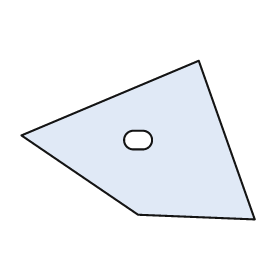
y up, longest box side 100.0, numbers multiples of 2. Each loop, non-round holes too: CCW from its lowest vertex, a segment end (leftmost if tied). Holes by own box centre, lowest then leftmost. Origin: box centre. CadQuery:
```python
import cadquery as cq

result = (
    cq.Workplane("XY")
    .moveTo(50.0, -34.0)
    .lineTo(26.0, 34.0)
    .lineTo(-50.0, 2.0)
    .lineTo(0.0, -32.0)
    .close()
    .moveTo(-2.0, -4.0)
    .lineTo(2.0, -4.0)
    .threePointArc((6.0, 0.0), (2.0, 4.0))
    .lineTo(-2.0, 4.0)
    .threePointArc((-6.0, 0.0), (-2.0, -4.0))
    .close()
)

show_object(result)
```